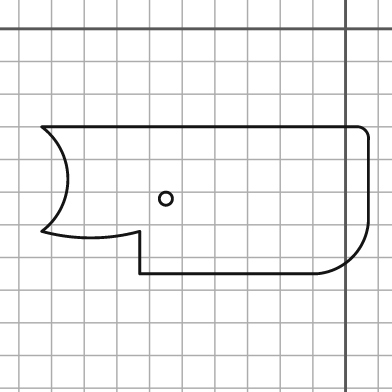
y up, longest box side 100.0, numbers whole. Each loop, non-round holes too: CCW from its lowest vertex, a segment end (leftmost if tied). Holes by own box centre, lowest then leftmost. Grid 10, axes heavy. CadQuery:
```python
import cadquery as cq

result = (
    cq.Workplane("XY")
    .moveTo(-63.0, -75.0)
    .lineTo(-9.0, -75.0)
    .threePointArc((2.0, -70.0), (7.0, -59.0))
    .lineTo(7.0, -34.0)
    .threePointArc((6.0, -31.0), (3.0, -30.0))
    .lineTo(-93.0, -30.0)
    .threePointArc((-85.0, -46.0), (-93.0, -62.0))
    .threePointArc((-78.0, -64.0), (-63.0, -62.0))
    .close()
    .moveTo(-55.0, -52.0)
    .circle(2.0)
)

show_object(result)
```